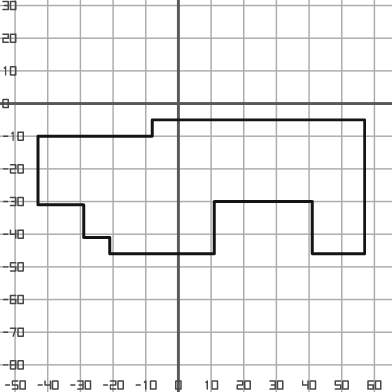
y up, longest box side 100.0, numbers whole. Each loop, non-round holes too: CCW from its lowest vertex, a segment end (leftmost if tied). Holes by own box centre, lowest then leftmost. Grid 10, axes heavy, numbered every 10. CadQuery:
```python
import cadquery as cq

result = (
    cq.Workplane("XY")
    .moveTo(-21.0, -46.0)
    .lineTo(11.0, -46.0)
    .lineTo(11.0, -30.0)
    .lineTo(41.0, -30.0)
    .lineTo(41.0, -46.0)
    .lineTo(57.0, -46.0)
    .lineTo(57.0, -5.0)
    .lineTo(-8.0, -5.0)
    .lineTo(-8.0, -10.0)
    .lineTo(-43.0, -10.0)
    .lineTo(-43.0, -31.0)
    .lineTo(-29.0, -31.0)
    .lineTo(-29.0, -41.0)
    .lineTo(-21.0, -41.0)
    .close()
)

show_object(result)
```